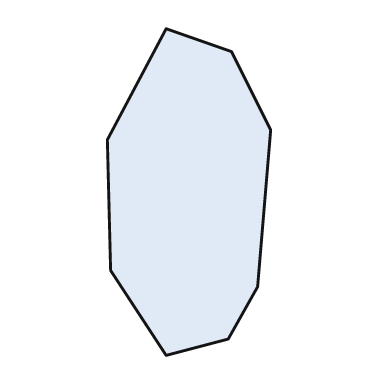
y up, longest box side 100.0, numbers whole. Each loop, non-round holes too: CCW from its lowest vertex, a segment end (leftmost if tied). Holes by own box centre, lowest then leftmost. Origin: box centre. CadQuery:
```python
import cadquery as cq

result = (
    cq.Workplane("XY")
    .moveTo(-7.0, -50.0)
    .lineTo(12.0, -45.0)
    .lineTo(21.0, -29.0)
    .lineTo(25.0, 19.0)
    .lineTo(13.0, 43.0)
    .lineTo(-7.0, 50.0)
    .lineTo(-25.0, 16.0)
    .lineTo(-24.0, -24.0)
    .close()
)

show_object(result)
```